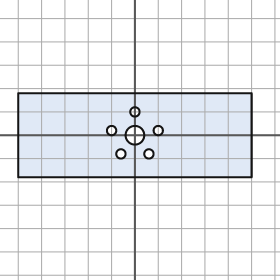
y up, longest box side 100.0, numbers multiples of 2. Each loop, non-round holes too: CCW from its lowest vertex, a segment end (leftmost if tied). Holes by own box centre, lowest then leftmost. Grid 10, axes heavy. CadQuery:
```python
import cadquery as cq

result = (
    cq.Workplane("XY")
    .moveTo(-50.0, -18.0)
    .lineTo(50.0, -18.0)
    .lineTo(50.0, 18.0)
    .lineTo(-50.0, 18.0)
    .close()
    .moveTo(-6.0, -8.0)
    .circle(2.0)
    .moveTo(6.0, -8.0)
    .circle(2.0)
    .moveTo(0.0, 0.0)
    .circle(4.0)
    .moveTo(-10.0, 2.0)
    .circle(2.0)
    .moveTo(10.0, 2.0)
    .circle(2.0)
    .moveTo(0.0, 10.0)
    .circle(2.0)
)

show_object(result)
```